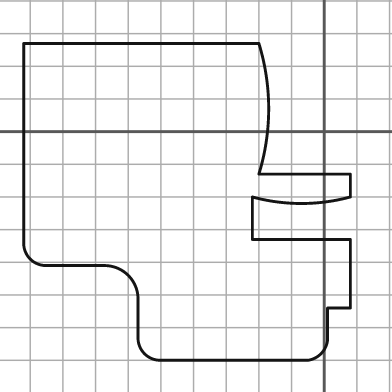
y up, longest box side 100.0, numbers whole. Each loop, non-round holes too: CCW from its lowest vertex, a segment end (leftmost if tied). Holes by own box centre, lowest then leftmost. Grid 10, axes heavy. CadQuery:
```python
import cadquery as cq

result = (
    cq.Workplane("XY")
    .moveTo(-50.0, -70.0)
    .lineTo(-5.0, -70.0)
    .threePointArc((-1.0, -68.0), (1.0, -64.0))
    .lineTo(1.0, -54.0)
    .lineTo(8.0, -54.0)
    .lineTo(8.0, -33.0)
    .lineTo(-22.0, -33.0)
    .lineTo(-22.0, -20.0)
    .threePointArc((-7.0, -22.0), (8.0, -20.0))
    .lineTo(8.0, -13.0)
    .lineTo(-20.0, -13.0)
    .threePointArc((-17.0, 7.0), (-20.0, 27.0))
    .lineTo(-92.0, 27.0)
    .lineTo(-92.0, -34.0)
    .threePointArc((-90.0, -39.0), (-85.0, -41.0))
    .lineTo(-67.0, -41.0)
    .threePointArc((-60.0, -44.0), (-57.0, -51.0))
    .lineTo(-57.0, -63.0)
    .threePointArc((-55.0, -68.0), (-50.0, -70.0))
    .close()
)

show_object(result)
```